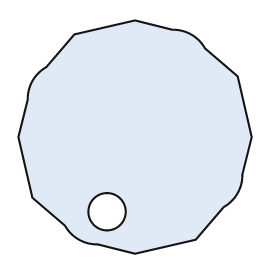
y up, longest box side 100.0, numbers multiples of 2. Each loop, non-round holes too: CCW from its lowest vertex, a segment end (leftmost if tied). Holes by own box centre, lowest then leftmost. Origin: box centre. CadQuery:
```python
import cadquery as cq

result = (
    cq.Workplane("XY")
    .moveTo(0.0, -50.0)
    .lineTo(26.0, -44.0)
    .lineTo(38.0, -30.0)
    .threePointArc((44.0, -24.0), (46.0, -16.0))
    .lineTo(50.0, 0.0)
    .lineTo(44.0, 26.0)
    .lineTo(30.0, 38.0)
    .threePointArc((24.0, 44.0), (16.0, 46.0))
    .lineTo(0.0, 50.0)
    .lineTo(-26.0, 44.0)
    .lineTo(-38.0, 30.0)
    .threePointArc((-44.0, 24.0), (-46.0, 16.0))
    .lineTo(-50.0, 0.0)
    .lineTo(-44.0, -26.0)
    .lineTo(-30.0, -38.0)
    .threePointArc((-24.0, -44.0), (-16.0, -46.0))
    .close()
    .moveTo(-12.0, -32.0)
    .circle(8.0)
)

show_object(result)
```